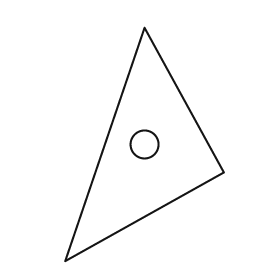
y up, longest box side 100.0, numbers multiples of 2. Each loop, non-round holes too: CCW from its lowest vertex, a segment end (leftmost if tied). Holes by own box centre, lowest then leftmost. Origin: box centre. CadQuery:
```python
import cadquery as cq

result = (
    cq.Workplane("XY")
    .moveTo(-34.0, -50.0)
    .lineTo(34.0, -12.0)
    .lineTo(0.0, 50.0)
    .close()
    .moveTo(0.0, 0.0)
    .circle(6.0)
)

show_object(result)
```